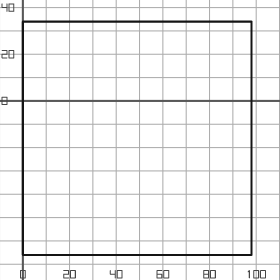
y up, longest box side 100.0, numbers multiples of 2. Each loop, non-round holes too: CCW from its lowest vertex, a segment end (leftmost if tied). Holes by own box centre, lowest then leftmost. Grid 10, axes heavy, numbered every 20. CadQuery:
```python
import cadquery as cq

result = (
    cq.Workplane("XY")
    .moveTo(0.0, -66.0)
    .lineTo(98.0, -66.0)
    .lineTo(98.0, 34.0)
    .lineTo(0.0, 34.0)
    .close()
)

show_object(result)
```